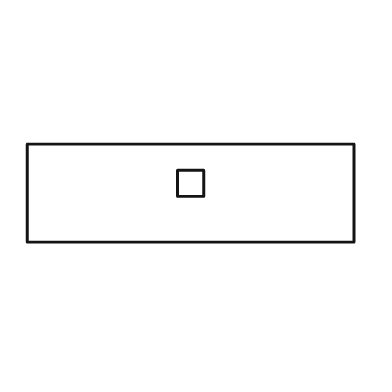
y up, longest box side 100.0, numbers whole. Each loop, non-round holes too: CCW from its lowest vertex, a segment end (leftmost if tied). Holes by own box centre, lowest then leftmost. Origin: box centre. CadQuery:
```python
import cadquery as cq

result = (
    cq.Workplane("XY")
    .moveTo(-50.0, -15.0)
    .lineTo(50.0, -15.0)
    .lineTo(50.0, 15.0)
    .lineTo(-50.0, 15.0)
    .close()
    .moveTo(-4.0, -1.0)
    .lineTo(4.0, -1.0)
    .lineTo(4.0, 7.0)
    .lineTo(-4.0, 7.0)
    .close()
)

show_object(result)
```